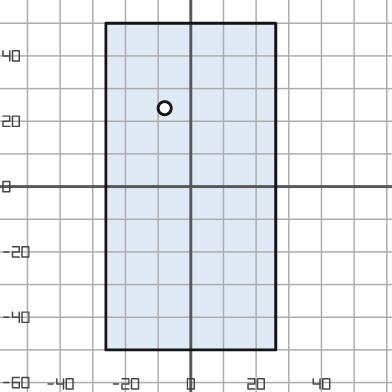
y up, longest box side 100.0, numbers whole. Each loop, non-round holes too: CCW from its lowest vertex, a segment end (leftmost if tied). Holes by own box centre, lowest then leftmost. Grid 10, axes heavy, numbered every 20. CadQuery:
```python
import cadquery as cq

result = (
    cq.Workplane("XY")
    .moveTo(-26.0, -50.0)
    .lineTo(26.0, -50.0)
    .lineTo(26.0, 50.0)
    .lineTo(-26.0, 50.0)
    .close()
    .moveTo(-8.0, 24.0)
    .circle(2.0)
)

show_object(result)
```